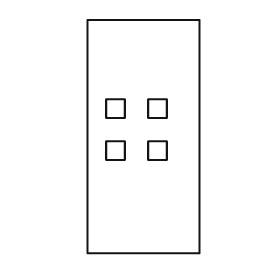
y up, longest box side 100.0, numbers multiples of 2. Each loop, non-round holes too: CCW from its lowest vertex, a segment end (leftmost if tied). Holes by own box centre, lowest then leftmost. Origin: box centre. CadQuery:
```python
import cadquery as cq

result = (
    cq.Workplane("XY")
    .moveTo(-24.0, -50.0)
    .lineTo(24.0, -50.0)
    .lineTo(24.0, 50.0)
    .lineTo(-24.0, 50.0)
    .close()
    .moveTo(-16.0, -10.0)
    .lineTo(-8.0, -10.0)
    .lineTo(-8.0, -2.0)
    .lineTo(-16.0, -2.0)
    .close()
    .moveTo(2.0, -10.0)
    .lineTo(10.0, -10.0)
    .lineTo(10.0, -2.0)
    .lineTo(2.0, -2.0)
    .close()
    .moveTo(-16.0, 8.0)
    .lineTo(-8.0, 8.0)
    .lineTo(-8.0, 16.0)
    .lineTo(-16.0, 16.0)
    .close()
    .moveTo(2.0, 8.0)
    .lineTo(10.0, 8.0)
    .lineTo(10.0, 16.0)
    .lineTo(2.0, 16.0)
    .close()
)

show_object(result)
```